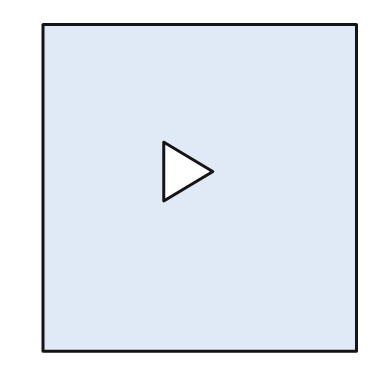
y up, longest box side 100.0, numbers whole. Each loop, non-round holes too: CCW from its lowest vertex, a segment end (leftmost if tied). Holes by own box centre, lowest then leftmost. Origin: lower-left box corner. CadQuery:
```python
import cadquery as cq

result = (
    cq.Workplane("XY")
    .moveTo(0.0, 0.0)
    .lineTo(96.0, 0.0)
    .lineTo(96.0, 100.0)
    .lineTo(0.0, 100.0)
    .close()
    .moveTo(37.0, 46.0)
    .lineTo(52.0, 55.0)
    .lineTo(37.0, 64.0)
    .close()
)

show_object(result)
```